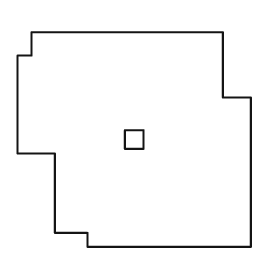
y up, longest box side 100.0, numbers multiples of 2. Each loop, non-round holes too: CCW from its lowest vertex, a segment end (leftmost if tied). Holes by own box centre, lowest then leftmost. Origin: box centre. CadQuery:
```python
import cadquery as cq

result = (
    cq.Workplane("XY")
    .moveTo(-20.0, -46.0)
    .lineTo(50.0, -46.0)
    .lineTo(50.0, 18.0)
    .lineTo(38.0, 18.0)
    .lineTo(38.0, 46.0)
    .lineTo(-44.0, 46.0)
    .lineTo(-44.0, 36.0)
    .lineTo(-50.0, 36.0)
    .lineTo(-50.0, -6.0)
    .lineTo(-34.0, -6.0)
    .lineTo(-34.0, -40.0)
    .lineTo(-20.0, -40.0)
    .close()
    .moveTo(-4.0, -4.0)
    .lineTo(4.0, -4.0)
    .lineTo(4.0, 4.0)
    .lineTo(-4.0, 4.0)
    .close()
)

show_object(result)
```